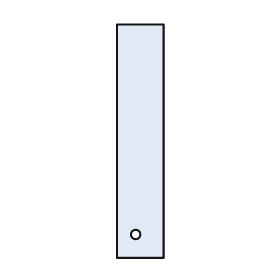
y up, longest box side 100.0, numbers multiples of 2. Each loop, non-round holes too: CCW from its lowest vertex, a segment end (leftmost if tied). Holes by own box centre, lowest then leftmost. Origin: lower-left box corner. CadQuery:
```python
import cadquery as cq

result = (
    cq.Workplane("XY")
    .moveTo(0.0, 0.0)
    .lineTo(20.0, 0.0)
    .lineTo(20.0, 100.0)
    .lineTo(0.0, 100.0)
    .close()
    .moveTo(8.0, 10.0)
    .circle(2.0)
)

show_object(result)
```